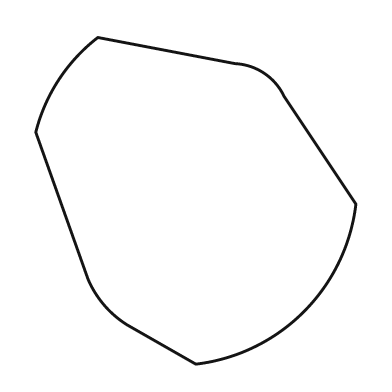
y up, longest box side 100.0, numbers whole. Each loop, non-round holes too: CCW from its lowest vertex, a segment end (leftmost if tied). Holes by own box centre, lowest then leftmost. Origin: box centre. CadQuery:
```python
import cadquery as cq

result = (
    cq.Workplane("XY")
    .moveTo(0.0, -50.0)
    .threePointArc((33.0, -34.0), (49.0, -1.0))
    .lineTo(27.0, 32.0)
    .threePointArc((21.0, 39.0), (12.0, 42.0))
    .lineTo(-30.0, 50.0)
    .threePointArc((-42.0, 37.0), (-49.0, 21.0))
    .lineTo(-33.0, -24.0)
    .threePointArc((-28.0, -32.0), (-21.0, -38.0))
    .close()
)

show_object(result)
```